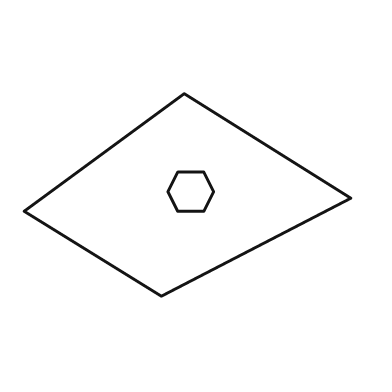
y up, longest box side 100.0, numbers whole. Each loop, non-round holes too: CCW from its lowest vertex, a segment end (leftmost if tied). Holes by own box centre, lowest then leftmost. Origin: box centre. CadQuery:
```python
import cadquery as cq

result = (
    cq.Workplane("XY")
    .moveTo(-8.0, -31.0)
    .lineTo(50.0, -1.0)
    .lineTo(-1.0, 31.0)
    .lineTo(-50.0, -5.0)
    .close()
    .moveTo(-3.0, -5.0)
    .lineTo(5.0, -5.0)
    .lineTo(8.0, 1.0)
    .lineTo(5.0, 7.0)
    .lineTo(-3.0, 7.0)
    .lineTo(-6.0, 1.0)
    .close()
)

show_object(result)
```